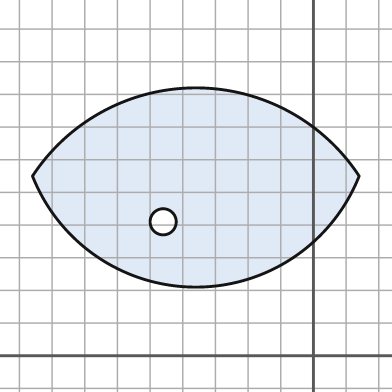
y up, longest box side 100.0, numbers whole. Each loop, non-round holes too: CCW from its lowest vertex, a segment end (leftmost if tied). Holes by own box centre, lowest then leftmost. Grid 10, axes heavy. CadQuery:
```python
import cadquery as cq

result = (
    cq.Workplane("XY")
    .moveTo(-86.0, 55.0)
    .threePointArc((-36.0, 21.0), (14.0, 55.0))
    .threePointArc((-36.0, 82.0), (-86.0, 55.0))
    .close()
    .moveTo(-46.0, 41.0)
    .circle(4.0)
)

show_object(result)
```